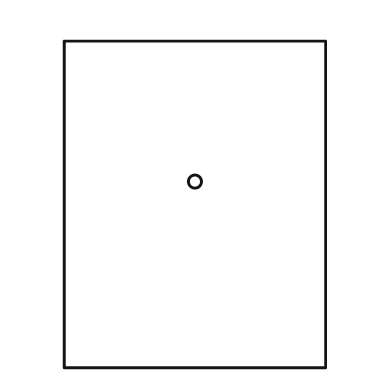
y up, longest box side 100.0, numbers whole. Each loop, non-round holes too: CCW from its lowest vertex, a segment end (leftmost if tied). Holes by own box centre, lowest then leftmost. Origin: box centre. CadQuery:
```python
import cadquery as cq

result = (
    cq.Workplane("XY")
    .moveTo(-40.0, -50.0)
    .lineTo(40.0, -50.0)
    .lineTo(40.0, 50.0)
    .lineTo(-40.0, 50.0)
    .close()
    .moveTo(0.0, 7.0)
    .circle(2.0)
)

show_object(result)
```